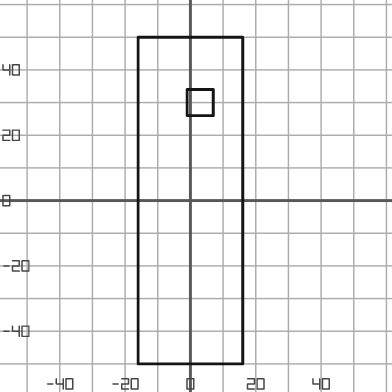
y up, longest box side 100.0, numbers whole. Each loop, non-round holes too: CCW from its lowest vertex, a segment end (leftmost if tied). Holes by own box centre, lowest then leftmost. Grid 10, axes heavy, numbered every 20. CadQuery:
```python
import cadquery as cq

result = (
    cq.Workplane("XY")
    .moveTo(-16.0, -50.0)
    .lineTo(16.0, -50.0)
    .lineTo(16.0, 50.0)
    .lineTo(-16.0, 50.0)
    .close()
    .moveTo(-1.0, 26.0)
    .lineTo(7.0, 26.0)
    .lineTo(7.0, 34.0)
    .lineTo(-1.0, 34.0)
    .close()
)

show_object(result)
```